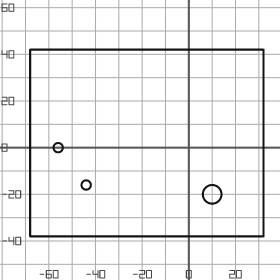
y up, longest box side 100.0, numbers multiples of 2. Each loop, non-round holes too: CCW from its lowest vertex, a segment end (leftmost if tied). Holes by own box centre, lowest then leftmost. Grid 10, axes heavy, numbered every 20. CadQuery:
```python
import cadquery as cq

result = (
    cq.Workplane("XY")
    .moveTo(-68.0, -38.0)
    .lineTo(32.0, -38.0)
    .lineTo(32.0, 42.0)
    .lineTo(-68.0, 42.0)
    .close()
    .moveTo(10.0, -20.0)
    .circle(4.0)
    .moveTo(-44.0, -16.0)
    .circle(2.0)
    .moveTo(-56.0, 0.0)
    .circle(2.0)
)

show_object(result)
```